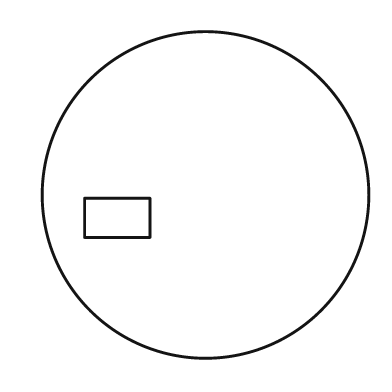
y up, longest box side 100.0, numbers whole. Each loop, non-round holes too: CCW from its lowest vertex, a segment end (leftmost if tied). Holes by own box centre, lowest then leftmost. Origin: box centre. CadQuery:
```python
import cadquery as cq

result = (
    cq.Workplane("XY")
    .moveTo(0.0, 0.0)
    .circle(50.0)
    .moveTo(-37.0, -13.0)
    .lineTo(-17.0, -13.0)
    .lineTo(-17.0, -1.0)
    .lineTo(-37.0, -1.0)
    .close()
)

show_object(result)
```